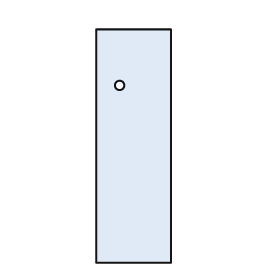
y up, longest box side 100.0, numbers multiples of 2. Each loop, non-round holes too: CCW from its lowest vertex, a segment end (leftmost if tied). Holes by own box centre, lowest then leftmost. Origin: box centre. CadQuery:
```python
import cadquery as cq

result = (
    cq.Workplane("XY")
    .moveTo(-16.0, -50.0)
    .lineTo(16.0, -50.0)
    .lineTo(16.0, 50.0)
    .lineTo(-16.0, 50.0)
    .close()
    .moveTo(-6.0, 26.0)
    .circle(2.0)
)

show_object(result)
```